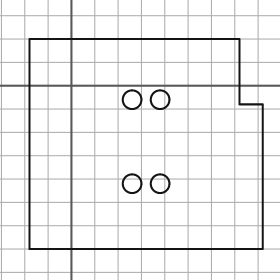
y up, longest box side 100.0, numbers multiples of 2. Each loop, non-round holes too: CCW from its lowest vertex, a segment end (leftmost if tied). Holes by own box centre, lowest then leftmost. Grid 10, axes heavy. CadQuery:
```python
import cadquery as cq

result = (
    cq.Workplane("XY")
    .moveTo(-18.0, -70.0)
    .lineTo(82.0, -70.0)
    .lineTo(82.0, -8.0)
    .lineTo(72.0, -8.0)
    .lineTo(72.0, 20.0)
    .lineTo(-18.0, 20.0)
    .close()
    .moveTo(26.0, -42.0)
    .circle(4.0)
    .moveTo(38.0, -42.0)
    .circle(4.0)
    .moveTo(26.0, -6.0)
    .circle(4.0)
    .moveTo(38.0, -6.0)
    .circle(4.0)
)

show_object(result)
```